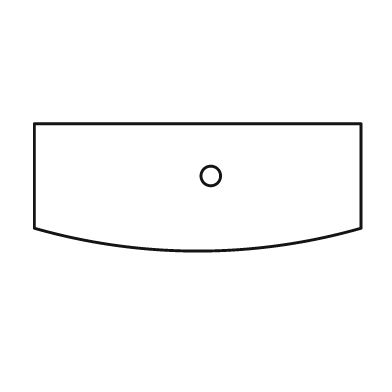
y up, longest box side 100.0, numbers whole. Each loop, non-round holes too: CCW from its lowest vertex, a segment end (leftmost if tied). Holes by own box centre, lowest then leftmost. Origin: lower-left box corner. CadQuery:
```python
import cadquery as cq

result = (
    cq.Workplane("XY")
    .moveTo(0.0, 7.0)
    .threePointArc((50.0, 0.0), (100.0, 7.0))
    .lineTo(100.0, 39.0)
    .lineTo(0.0, 39.0)
    .close()
    .moveTo(54.0, 23.0)
    .circle(3.0)
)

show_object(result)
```